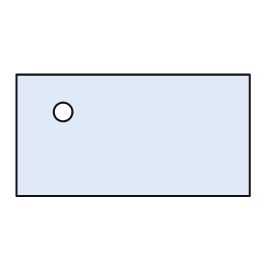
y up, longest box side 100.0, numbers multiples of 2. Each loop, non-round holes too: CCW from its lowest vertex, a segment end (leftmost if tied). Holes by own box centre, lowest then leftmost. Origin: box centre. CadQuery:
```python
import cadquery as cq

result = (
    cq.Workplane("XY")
    .moveTo(-50.0, -26.0)
    .lineTo(50.0, -26.0)
    .lineTo(50.0, 26.0)
    .lineTo(-50.0, 26.0)
    .close()
    .moveTo(-30.0, 10.0)
    .circle(4.0)
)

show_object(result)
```